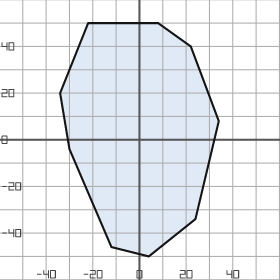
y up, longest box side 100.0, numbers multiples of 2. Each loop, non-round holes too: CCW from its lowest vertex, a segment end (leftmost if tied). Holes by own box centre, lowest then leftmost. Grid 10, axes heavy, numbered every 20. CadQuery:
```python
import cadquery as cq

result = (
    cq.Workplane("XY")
    .moveTo(4.0, -50.0)
    .lineTo(24.0, -34.0)
    .lineTo(34.0, 8.0)
    .lineTo(22.0, 40.0)
    .lineTo(8.0, 50.0)
    .lineTo(-22.0, 50.0)
    .lineTo(-34.0, 20.0)
    .lineTo(-30.0, -4.0)
    .lineTo(-12.0, -46.0)
    .close()
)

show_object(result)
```